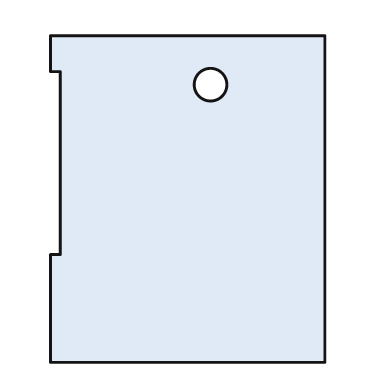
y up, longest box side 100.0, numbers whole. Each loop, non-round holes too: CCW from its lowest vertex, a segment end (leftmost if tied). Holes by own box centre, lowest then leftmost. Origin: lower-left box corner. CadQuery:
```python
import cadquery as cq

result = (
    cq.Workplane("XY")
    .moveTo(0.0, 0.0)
    .lineTo(84.0, 0.0)
    .lineTo(84.0, 100.0)
    .lineTo(0.0, 100.0)
    .lineTo(0.0, 89.0)
    .lineTo(3.0, 89.0)
    .lineTo(3.0, 33.0)
    .lineTo(0.0, 33.0)
    .close()
    .moveTo(49.0, 85.0)
    .circle(5.0)
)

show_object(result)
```